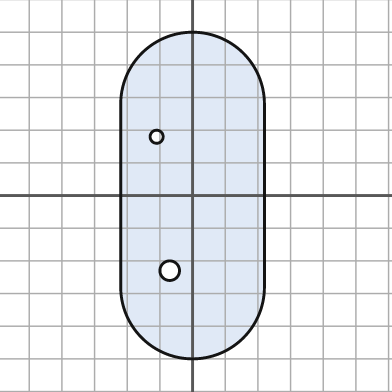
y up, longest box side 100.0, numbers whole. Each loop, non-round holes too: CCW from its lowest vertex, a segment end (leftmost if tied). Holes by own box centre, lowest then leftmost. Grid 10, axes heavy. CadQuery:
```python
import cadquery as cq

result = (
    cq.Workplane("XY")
    .moveTo(-22.0, -28.0)
    .threePointArc((0.0, -50.0), (22.0, -28.0))
    .lineTo(22.0, 28.0)
    .threePointArc((0.0, 50.0), (-22.0, 28.0))
    .close()
    .moveTo(-7.0, -23.0)
    .circle(3.0)
    .moveTo(-11.0, 18.0)
    .circle(2.0)
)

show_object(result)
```